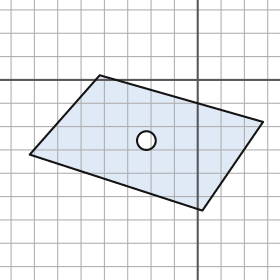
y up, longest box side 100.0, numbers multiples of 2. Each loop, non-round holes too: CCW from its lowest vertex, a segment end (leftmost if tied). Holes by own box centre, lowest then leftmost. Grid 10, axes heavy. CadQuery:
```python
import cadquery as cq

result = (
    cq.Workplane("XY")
    .moveTo(2.0, -56.0)
    .lineTo(28.0, -18.0)
    .lineTo(-42.0, 2.0)
    .lineTo(-72.0, -32.0)
    .close()
    .moveTo(-22.0, -26.0)
    .circle(4.0)
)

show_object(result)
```